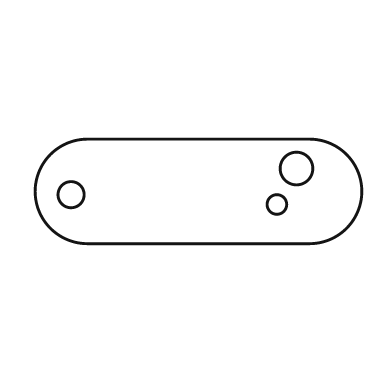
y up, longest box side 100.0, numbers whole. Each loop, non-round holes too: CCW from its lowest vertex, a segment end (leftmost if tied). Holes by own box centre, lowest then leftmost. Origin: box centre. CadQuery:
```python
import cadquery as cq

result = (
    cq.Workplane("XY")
    .moveTo(-34.0, -16.0)
    .lineTo(34.0, -16.0)
    .threePointArc((50.0, 0.0), (34.0, 16.0))
    .lineTo(-34.0, 16.0)
    .threePointArc((-50.0, 0.0), (-34.0, -16.0))
    .close()
    .moveTo(24.0, -4.0)
    .circle(3.0)
    .moveTo(-39.0, -1.0)
    .circle(4.0)
    .moveTo(30.0, 7.0)
    .circle(5.0)
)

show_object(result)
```